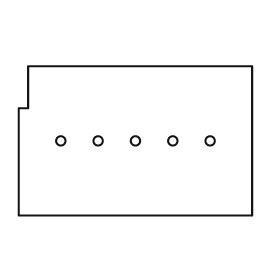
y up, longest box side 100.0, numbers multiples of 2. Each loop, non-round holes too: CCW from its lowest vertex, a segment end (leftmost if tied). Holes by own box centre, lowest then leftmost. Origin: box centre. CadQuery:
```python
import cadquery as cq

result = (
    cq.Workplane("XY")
    .moveTo(-50.0, -32.0)
    .lineTo(50.0, -32.0)
    .lineTo(50.0, 32.0)
    .lineTo(-46.0, 32.0)
    .lineTo(-46.0, 14.0)
    .lineTo(-50.0, 14.0)
    .close()
    .moveTo(-32.0, 0.0)
    .circle(2.0)
    .moveTo(-16.0, 0.0)
    .circle(2.0)
    .moveTo(0.0, 0.0)
    .circle(2.0)
    .moveTo(16.0, 0.0)
    .circle(2.0)
    .moveTo(32.0, 0.0)
    .circle(2.0)
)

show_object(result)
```